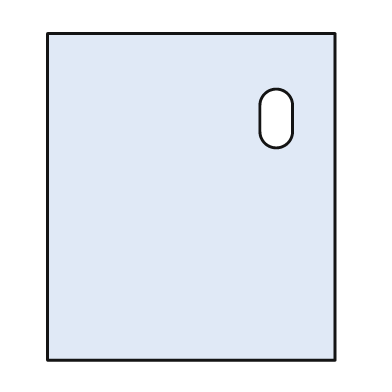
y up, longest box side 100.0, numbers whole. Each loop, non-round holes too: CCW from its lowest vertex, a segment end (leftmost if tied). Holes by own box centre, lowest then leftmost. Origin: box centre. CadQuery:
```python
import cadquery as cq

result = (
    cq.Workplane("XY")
    .moveTo(-44.0, -50.0)
    .lineTo(44.0, -50.0)
    .lineTo(44.0, 50.0)
    .lineTo(-44.0, 50.0)
    .close()
    .moveTo(21.0, 20.0)
    .threePointArc((26.0, 15.0), (31.0, 20.0))
    .lineTo(31.0, 28.0)
    .threePointArc((26.0, 33.0), (21.0, 28.0))
    .close()
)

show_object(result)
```